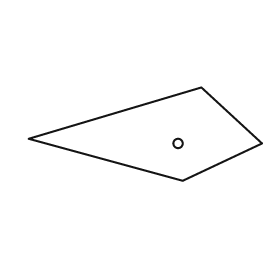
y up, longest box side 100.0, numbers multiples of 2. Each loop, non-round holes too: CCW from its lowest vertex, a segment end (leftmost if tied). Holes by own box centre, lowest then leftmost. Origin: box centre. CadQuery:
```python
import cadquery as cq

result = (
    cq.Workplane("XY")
    .moveTo(16.0, -20.0)
    .lineTo(50.0, -4.0)
    .lineTo(24.0, 20.0)
    .lineTo(-50.0, -2.0)
    .close()
    .moveTo(14.0, -4.0)
    .circle(2.0)
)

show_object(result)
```